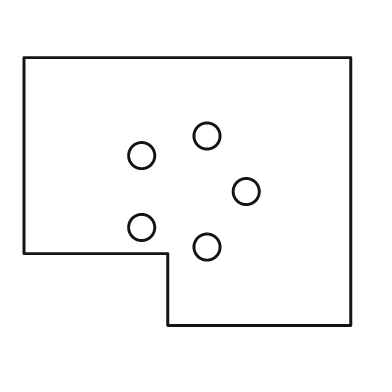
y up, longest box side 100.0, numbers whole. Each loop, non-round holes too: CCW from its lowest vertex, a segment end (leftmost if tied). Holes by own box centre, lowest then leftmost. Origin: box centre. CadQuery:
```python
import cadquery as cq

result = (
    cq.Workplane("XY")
    .moveTo(-6.0, -41.0)
    .lineTo(50.0, -41.0)
    .lineTo(50.0, 41.0)
    .lineTo(-50.0, 41.0)
    .lineTo(-50.0, -19.0)
    .lineTo(-6.0, -19.0)
    .close()
    .moveTo(6.0, -17.0)
    .circle(4.0)
    .moveTo(-14.0, -11.0)
    .circle(4.0)
    .moveTo(18.0, 0.0)
    .circle(4.0)
    .moveTo(-14.0, 11.0)
    .circle(4.0)
    .moveTo(6.0, 17.0)
    .circle(4.0)
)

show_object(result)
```